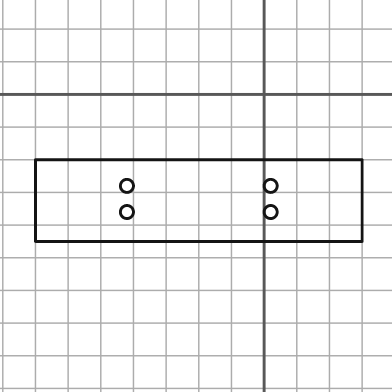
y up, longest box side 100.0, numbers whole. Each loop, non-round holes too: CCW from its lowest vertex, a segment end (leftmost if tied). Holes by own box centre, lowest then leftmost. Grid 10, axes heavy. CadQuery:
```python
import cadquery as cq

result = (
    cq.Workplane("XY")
    .moveTo(-70.0, -45.0)
    .lineTo(30.0, -45.0)
    .lineTo(30.0, -20.0)
    .lineTo(-70.0, -20.0)
    .close()
    .moveTo(-42.0, -36.0)
    .circle(2.0)
    .moveTo(2.0, -36.0)
    .circle(2.0)
    .moveTo(-42.0, -28.0)
    .circle(2.0)
    .moveTo(2.0, -28.0)
    .circle(2.0)
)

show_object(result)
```